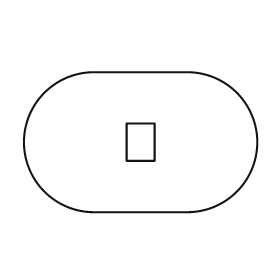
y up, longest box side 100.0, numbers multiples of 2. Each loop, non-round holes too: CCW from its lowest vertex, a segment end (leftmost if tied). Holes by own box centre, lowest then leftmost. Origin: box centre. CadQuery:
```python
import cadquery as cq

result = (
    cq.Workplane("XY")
    .moveTo(-20.0, -30.0)
    .lineTo(20.0, -30.0)
    .threePointArc((50.0, 0.0), (20.0, 30.0))
    .lineTo(-20.0, 30.0)
    .threePointArc((-50.0, 0.0), (-20.0, -30.0))
    .close()
    .moveTo(-6.0, -8.0)
    .lineTo(6.0, -8.0)
    .lineTo(6.0, 8.0)
    .lineTo(-6.0, 8.0)
    .close()
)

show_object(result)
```